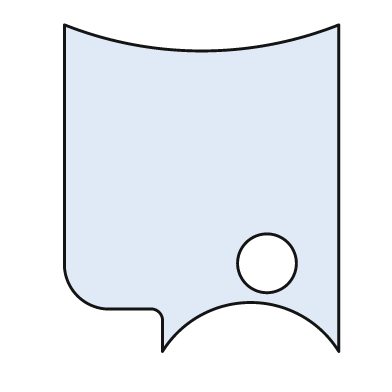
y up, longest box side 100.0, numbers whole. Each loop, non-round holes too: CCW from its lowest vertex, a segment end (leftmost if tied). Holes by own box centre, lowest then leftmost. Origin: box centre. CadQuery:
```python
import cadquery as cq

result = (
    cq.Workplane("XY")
    .moveTo(-12.0, -50.0)
    .threePointArc((15.0, -35.0), (42.0, -50.0))
    .lineTo(42.0, 50.0)
    .threePointArc((0.0, 42.0), (-42.0, 50.0))
    .lineTo(-42.0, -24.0)
    .threePointArc((-38.0, -33.0), (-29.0, -37.0))
    .lineTo(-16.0, -37.0)
    .threePointArc((-13.0, -38.0), (-12.0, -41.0))
    .close()
    .moveTo(20.0, -23.0)
    .circle(9.0)
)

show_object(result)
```